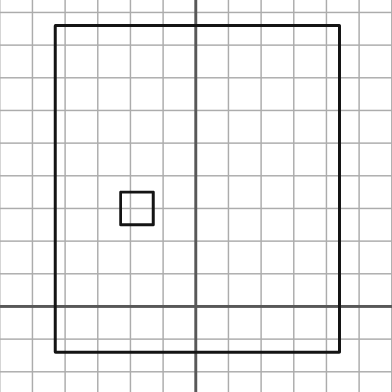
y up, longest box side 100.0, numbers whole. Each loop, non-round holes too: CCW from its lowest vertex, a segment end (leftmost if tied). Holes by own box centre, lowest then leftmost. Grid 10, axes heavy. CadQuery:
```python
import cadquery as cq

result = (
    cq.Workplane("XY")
    .moveTo(-43.0, -14.0)
    .lineTo(44.0, -14.0)
    .lineTo(44.0, 86.0)
    .lineTo(-43.0, 86.0)
    .close()
    .moveTo(-23.0, 25.0)
    .lineTo(-13.0, 25.0)
    .lineTo(-13.0, 35.0)
    .lineTo(-23.0, 35.0)
    .close()
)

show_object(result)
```